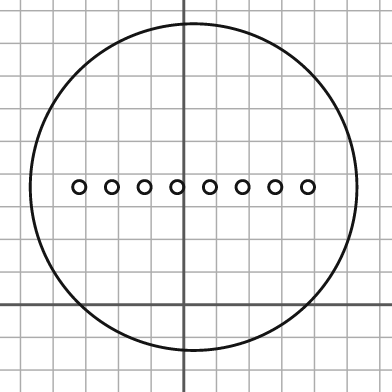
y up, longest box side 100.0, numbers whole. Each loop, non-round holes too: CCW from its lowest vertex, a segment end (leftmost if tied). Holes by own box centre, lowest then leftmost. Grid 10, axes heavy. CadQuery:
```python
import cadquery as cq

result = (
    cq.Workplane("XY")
    .moveTo(3.0, 36.0)
    .circle(50.0)
    .moveTo(-32.0, 36.0)
    .circle(2.0)
    .moveTo(-22.0, 36.0)
    .circle(2.0)
    .moveTo(-12.0, 36.0)
    .circle(2.0)
    .moveTo(-2.0, 36.0)
    .circle(2.0)
    .moveTo(8.0, 36.0)
    .circle(2.0)
    .moveTo(18.0, 36.0)
    .circle(2.0)
    .moveTo(28.0, 36.0)
    .circle(2.0)
    .moveTo(38.0, 36.0)
    .circle(2.0)
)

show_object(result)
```